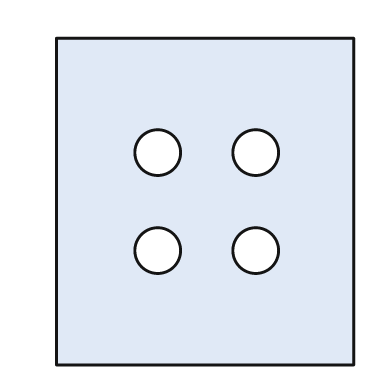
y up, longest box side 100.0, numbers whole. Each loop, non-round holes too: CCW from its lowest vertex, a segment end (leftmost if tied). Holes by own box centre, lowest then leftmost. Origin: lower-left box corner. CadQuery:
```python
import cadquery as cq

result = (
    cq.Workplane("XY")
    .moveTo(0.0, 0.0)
    .lineTo(91.0, 0.0)
    .lineTo(91.0, 100.0)
    .lineTo(0.0, 100.0)
    .close()
    .moveTo(31.0, 35.0)
    .circle(7.0)
    .moveTo(61.0, 35.0)
    .circle(7.0)
    .moveTo(31.0, 65.0)
    .circle(7.0)
    .moveTo(61.0, 65.0)
    .circle(7.0)
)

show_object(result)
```